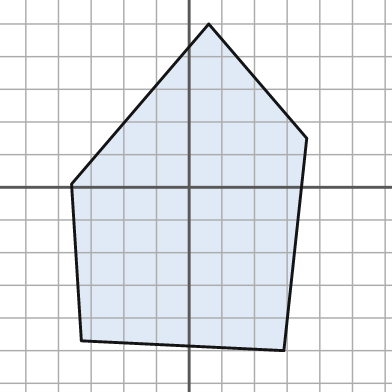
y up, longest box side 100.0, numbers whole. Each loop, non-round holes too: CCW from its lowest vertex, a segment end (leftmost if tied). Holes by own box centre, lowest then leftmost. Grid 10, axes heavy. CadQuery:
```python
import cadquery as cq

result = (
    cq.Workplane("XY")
    .moveTo(29.0, -50.0)
    .lineTo(36.0, 15.0)
    .lineTo(6.0, 50.0)
    .lineTo(-36.0, 1.0)
    .lineTo(-33.0, -47.0)
    .close()
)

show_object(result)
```